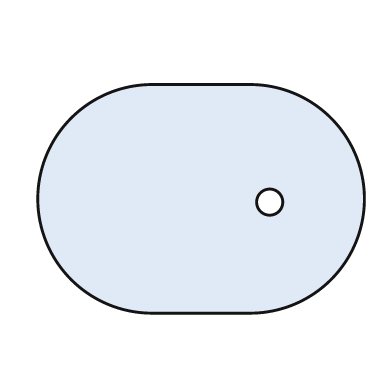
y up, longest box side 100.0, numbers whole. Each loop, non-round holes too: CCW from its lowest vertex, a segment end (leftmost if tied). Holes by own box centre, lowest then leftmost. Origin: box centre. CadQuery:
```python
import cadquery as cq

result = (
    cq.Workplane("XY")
    .moveTo(-15.0, -35.0)
    .lineTo(15.0, -35.0)
    .threePointArc((50.0, 0.0), (15.0, 35.0))
    .lineTo(-15.0, 35.0)
    .threePointArc((-50.0, 0.0), (-15.0, -35.0))
    .close()
    .moveTo(21.0, -1.0)
    .circle(4.0)
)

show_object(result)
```